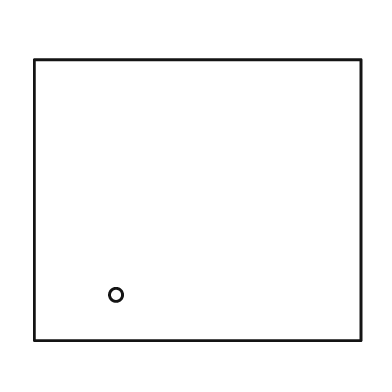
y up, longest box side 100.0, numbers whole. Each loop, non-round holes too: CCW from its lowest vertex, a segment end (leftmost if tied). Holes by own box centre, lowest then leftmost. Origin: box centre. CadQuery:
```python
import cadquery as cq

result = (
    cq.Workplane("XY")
    .moveTo(-50.0, -43.0)
    .lineTo(50.0, -43.0)
    .lineTo(50.0, 43.0)
    .lineTo(-50.0, 43.0)
    .close()
    .moveTo(-25.0, -29.0)
    .circle(2.0)
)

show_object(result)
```